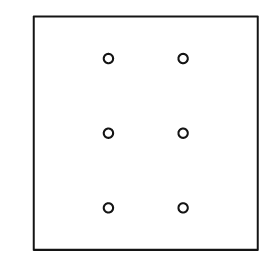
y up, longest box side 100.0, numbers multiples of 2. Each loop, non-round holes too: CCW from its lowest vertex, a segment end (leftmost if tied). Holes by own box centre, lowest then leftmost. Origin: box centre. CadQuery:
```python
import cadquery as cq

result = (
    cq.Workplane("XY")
    .moveTo(-48.0, -50.0)
    .lineTo(48.0, -50.0)
    .lineTo(48.0, 50.0)
    .lineTo(-48.0, 50.0)
    .close()
    .moveTo(-16.0, -32.0)
    .circle(2.0)
    .moveTo(16.0, -32.0)
    .circle(2.0)
    .moveTo(-16.0, 0.0)
    .circle(2.0)
    .moveTo(16.0, 0.0)
    .circle(2.0)
    .moveTo(-16.0, 32.0)
    .circle(2.0)
    .moveTo(16.0, 32.0)
    .circle(2.0)
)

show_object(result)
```